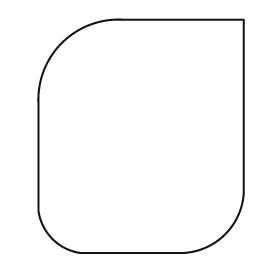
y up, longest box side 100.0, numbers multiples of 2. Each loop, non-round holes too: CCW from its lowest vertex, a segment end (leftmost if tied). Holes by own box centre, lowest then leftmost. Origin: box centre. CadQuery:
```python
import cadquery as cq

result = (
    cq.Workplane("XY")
    .moveTo(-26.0, -50.0)
    .lineTo(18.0, -50.0)
    .threePointArc((36.0, -42.0), (44.0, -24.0))
    .lineTo(44.0, 50.0)
    .lineTo(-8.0, 50.0)
    .threePointArc((-34.0, 40.0), (-44.0, 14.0))
    .lineTo(-44.0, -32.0)
    .threePointArc((-38.0, -44.0), (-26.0, -50.0))
    .close()
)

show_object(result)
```